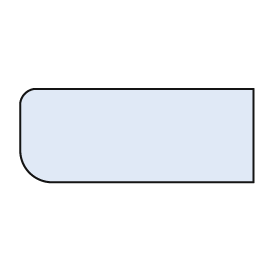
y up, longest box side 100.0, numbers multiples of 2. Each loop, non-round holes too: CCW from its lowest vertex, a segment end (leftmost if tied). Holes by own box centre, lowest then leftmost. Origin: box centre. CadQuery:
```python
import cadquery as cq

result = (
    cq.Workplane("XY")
    .moveTo(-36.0, -20.0)
    .lineTo(50.0, -20.0)
    .lineTo(50.0, 20.0)
    .lineTo(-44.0, 20.0)
    .threePointArc((-48.0, 18.0), (-50.0, 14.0))
    .lineTo(-50.0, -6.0)
    .threePointArc((-46.0, -16.0), (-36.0, -20.0))
    .close()
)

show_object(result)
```